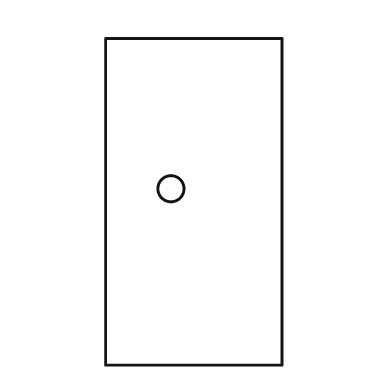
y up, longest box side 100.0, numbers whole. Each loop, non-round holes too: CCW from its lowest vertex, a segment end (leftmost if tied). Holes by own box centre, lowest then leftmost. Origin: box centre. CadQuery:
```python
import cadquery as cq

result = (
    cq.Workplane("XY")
    .moveTo(-27.0, -50.0)
    .lineTo(27.0, -50.0)
    .lineTo(27.0, 50.0)
    .lineTo(-27.0, 50.0)
    .close()
    .moveTo(-7.0, 4.0)
    .circle(4.0)
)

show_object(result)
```